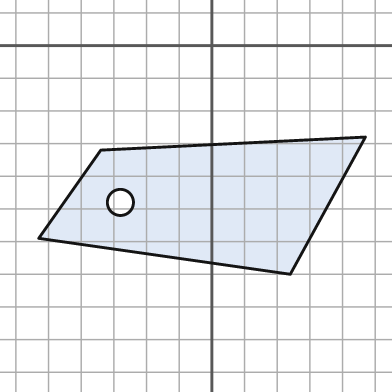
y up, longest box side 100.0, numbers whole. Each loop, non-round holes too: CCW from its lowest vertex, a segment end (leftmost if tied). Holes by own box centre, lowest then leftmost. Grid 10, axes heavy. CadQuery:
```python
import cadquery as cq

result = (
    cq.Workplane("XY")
    .moveTo(24.0, -70.0)
    .lineTo(47.0, -28.0)
    .lineTo(-34.0, -32.0)
    .lineTo(-53.0, -59.0)
    .close()
    .moveTo(-28.0, -48.0)
    .circle(4.0)
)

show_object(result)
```